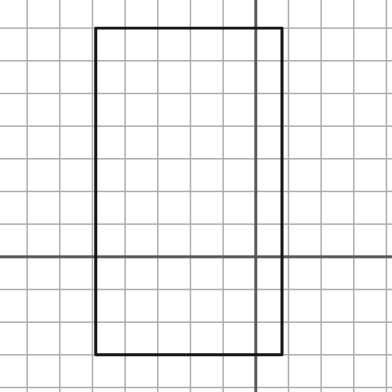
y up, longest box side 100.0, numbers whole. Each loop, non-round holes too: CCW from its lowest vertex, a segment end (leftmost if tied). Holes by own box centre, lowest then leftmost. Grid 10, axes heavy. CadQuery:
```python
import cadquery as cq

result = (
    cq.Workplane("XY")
    .moveTo(-49.0, -30.0)
    .lineTo(8.0, -30.0)
    .lineTo(8.0, 70.0)
    .lineTo(-49.0, 70.0)
    .close()
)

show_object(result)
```